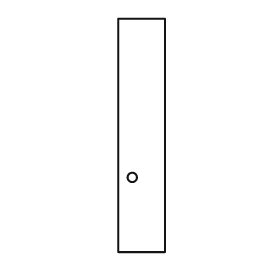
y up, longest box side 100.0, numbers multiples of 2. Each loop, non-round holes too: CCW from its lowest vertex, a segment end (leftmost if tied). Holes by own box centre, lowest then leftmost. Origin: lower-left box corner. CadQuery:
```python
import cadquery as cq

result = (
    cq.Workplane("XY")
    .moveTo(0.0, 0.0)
    .lineTo(20.0, 0.0)
    .lineTo(20.0, 100.0)
    .lineTo(0.0, 100.0)
    .close()
    .moveTo(6.0, 32.0)
    .circle(2.0)
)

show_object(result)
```